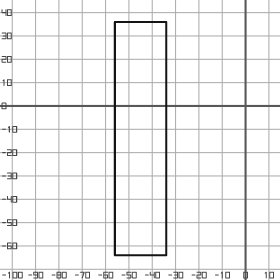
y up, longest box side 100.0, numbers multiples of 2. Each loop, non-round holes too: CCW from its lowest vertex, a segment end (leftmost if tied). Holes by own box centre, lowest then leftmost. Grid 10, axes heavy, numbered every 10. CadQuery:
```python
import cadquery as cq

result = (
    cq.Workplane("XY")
    .moveTo(-56.0, -64.0)
    .lineTo(-34.0, -64.0)
    .lineTo(-34.0, 36.0)
    .lineTo(-56.0, 36.0)
    .close()
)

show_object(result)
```